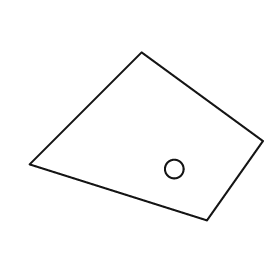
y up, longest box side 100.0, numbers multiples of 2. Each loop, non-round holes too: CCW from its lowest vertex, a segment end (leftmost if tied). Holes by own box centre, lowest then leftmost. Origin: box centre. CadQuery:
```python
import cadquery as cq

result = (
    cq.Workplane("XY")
    .moveTo(26.0, -36.0)
    .lineTo(50.0, -2.0)
    .lineTo(-2.0, 36.0)
    .lineTo(-50.0, -12.0)
    .close()
    .moveTo(12.0, -14.0)
    .circle(4.0)
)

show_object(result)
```